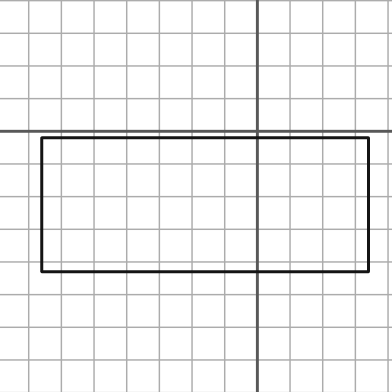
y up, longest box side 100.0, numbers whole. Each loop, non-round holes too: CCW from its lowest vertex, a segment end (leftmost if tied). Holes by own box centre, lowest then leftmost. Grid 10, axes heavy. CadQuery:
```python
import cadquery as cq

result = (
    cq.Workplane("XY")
    .moveTo(-66.0, -43.0)
    .lineTo(34.0, -43.0)
    .lineTo(34.0, -2.0)
    .lineTo(-66.0, -2.0)
    .close()
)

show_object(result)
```